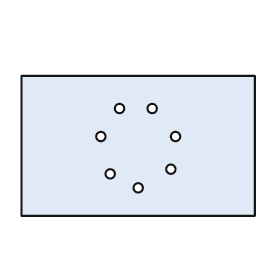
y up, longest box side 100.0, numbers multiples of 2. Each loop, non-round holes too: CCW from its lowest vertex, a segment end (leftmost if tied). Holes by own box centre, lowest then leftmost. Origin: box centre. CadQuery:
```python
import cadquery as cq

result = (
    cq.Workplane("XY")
    .moveTo(-50.0, -30.0)
    .lineTo(50.0, -30.0)
    .lineTo(50.0, 30.0)
    .lineTo(-50.0, 30.0)
    .close()
    .moveTo(0.0, -18.0)
    .circle(2.0)
    .moveTo(-12.0, -12.0)
    .circle(2.0)
    .moveTo(14.0, -10.0)
    .circle(2.0)
    .moveTo(-16.0, 4.0)
    .circle(2.0)
    .moveTo(16.0, 4.0)
    .circle(2.0)
    .moveTo(-8.0, 16.0)
    .circle(2.0)
    .moveTo(6.0, 16.0)
    .circle(2.0)
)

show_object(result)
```